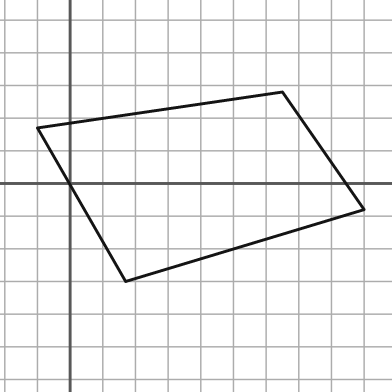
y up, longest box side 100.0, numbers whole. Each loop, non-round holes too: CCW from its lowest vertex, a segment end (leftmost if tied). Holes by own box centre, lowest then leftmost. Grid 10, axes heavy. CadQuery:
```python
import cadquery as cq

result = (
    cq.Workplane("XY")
    .moveTo(17.0, -30.0)
    .lineTo(90.0, -8.0)
    .lineTo(65.0, 28.0)
    .lineTo(-10.0, 17.0)
    .close()
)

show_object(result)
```